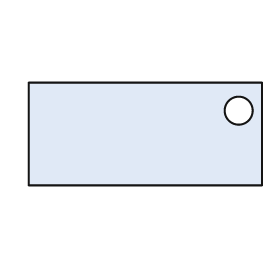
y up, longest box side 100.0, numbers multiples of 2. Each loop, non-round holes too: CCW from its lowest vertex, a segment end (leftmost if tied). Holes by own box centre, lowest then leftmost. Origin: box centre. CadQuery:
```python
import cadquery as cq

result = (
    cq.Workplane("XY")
    .moveTo(-50.0, -22.0)
    .lineTo(50.0, -22.0)
    .lineTo(50.0, 22.0)
    .lineTo(-50.0, 22.0)
    .close()
    .moveTo(40.0, 10.0)
    .circle(6.0)
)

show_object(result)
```